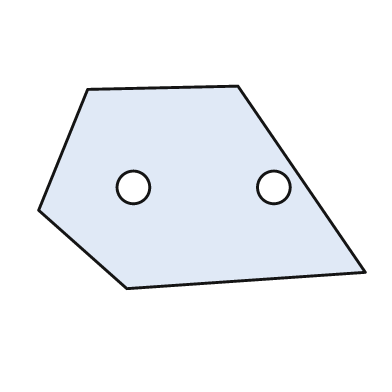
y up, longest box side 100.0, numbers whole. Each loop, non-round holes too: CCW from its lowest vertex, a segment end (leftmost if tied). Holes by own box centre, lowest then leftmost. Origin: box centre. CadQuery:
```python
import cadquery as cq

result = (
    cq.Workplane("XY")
    .moveTo(-23.0, -31.0)
    .lineTo(50.0, -26.0)
    .lineTo(11.0, 31.0)
    .lineTo(-35.0, 30.0)
    .lineTo(-50.0, -7.0)
    .close()
    .moveTo(-21.0, 0.0)
    .circle(5.0)
    .moveTo(22.0, 0.0)
    .circle(5.0)
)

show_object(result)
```